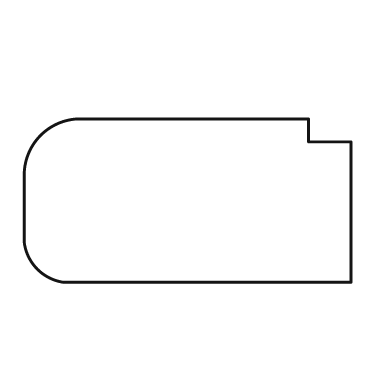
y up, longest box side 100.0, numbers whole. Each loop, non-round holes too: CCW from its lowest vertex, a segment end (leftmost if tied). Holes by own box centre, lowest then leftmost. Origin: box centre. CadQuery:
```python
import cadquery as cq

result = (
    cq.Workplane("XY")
    .moveTo(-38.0, -25.0)
    .lineTo(50.0, -25.0)
    .lineTo(50.0, 18.0)
    .lineTo(37.0, 18.0)
    .lineTo(37.0, 25.0)
    .lineTo(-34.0, 25.0)
    .threePointArc((-45.0, 20.0), (-50.0, 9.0))
    .lineTo(-50.0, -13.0)
    .threePointArc((-46.0, -21.0), (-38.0, -25.0))
    .close()
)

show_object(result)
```